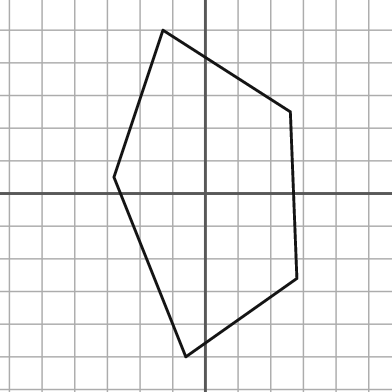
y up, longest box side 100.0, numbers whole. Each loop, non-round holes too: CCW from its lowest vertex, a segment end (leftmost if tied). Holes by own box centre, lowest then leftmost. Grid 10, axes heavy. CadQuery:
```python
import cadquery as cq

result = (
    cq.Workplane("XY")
    .moveTo(-6.0, -50.0)
    .lineTo(28.0, -26.0)
    .lineTo(26.0, 25.0)
    .lineTo(-13.0, 50.0)
    .lineTo(-28.0, 5.0)
    .close()
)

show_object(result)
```